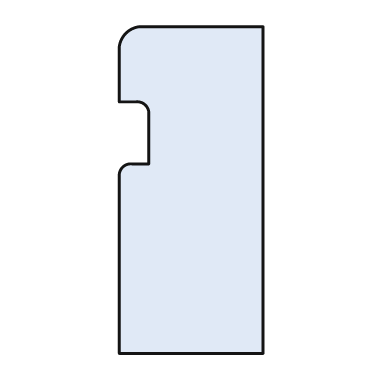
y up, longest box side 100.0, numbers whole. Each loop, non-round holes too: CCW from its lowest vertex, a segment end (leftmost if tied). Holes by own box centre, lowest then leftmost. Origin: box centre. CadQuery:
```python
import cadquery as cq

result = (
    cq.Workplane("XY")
    .moveTo(-22.0, -50.0)
    .lineTo(22.0, -50.0)
    .lineTo(22.0, 50.0)
    .lineTo(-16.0, 50.0)
    .threePointArc((-20.0, 48.0), (-22.0, 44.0))
    .lineTo(-22.0, 27.0)
    .lineTo(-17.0, 27.0)
    .threePointArc((-14.0, 26.0), (-13.0, 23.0))
    .lineTo(-13.0, 8.0)
    .lineTo(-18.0, 8.0)
    .threePointArc((-21.0, 7.0), (-22.0, 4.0))
    .close()
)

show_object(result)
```